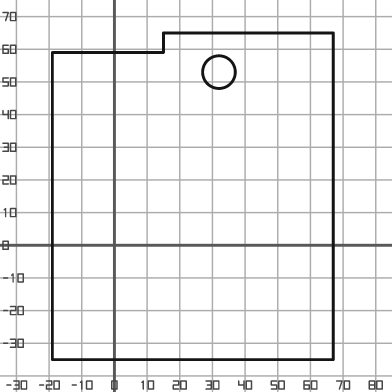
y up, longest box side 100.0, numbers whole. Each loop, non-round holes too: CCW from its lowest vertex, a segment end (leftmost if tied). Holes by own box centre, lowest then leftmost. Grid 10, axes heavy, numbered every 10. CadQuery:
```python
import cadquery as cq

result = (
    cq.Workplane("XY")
    .moveTo(-19.0, -35.0)
    .lineTo(67.0, -35.0)
    .lineTo(67.0, 65.0)
    .lineTo(15.0, 65.0)
    .lineTo(15.0, 59.0)
    .lineTo(-19.0, 59.0)
    .close()
    .moveTo(32.0, 53.0)
    .circle(5.0)
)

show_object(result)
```